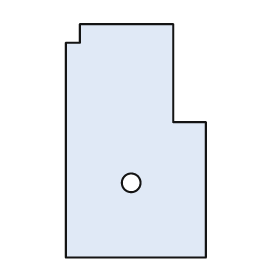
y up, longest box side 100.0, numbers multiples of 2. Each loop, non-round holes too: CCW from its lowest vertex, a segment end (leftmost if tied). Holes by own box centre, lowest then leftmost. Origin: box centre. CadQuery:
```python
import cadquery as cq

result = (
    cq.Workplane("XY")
    .moveTo(-30.0, -50.0)
    .lineTo(30.0, -50.0)
    .lineTo(30.0, 8.0)
    .lineTo(16.0, 8.0)
    .lineTo(16.0, 50.0)
    .lineTo(-24.0, 50.0)
    .lineTo(-24.0, 42.0)
    .lineTo(-30.0, 42.0)
    .close()
    .moveTo(-2.0, -18.0)
    .circle(4.0)
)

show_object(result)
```